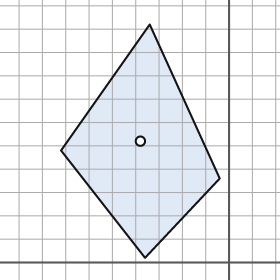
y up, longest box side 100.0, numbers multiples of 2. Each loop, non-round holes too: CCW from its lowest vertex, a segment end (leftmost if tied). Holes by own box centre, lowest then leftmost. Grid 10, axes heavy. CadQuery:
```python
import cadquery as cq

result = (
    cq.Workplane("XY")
    .moveTo(-36.0, 2.0)
    .lineTo(-4.0, 36.0)
    .lineTo(-34.0, 102.0)
    .lineTo(-72.0, 48.0)
    .close()
    .moveTo(-38.0, 52.0)
    .circle(2.0)
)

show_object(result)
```